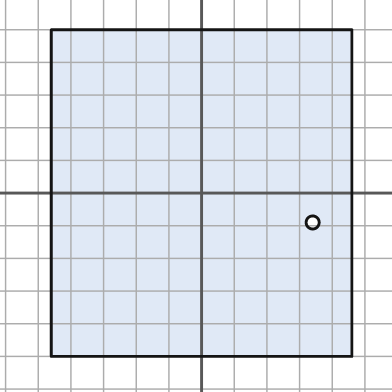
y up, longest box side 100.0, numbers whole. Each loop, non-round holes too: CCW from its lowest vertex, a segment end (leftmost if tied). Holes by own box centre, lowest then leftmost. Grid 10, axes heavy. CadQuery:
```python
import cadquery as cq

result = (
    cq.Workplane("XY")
    .moveTo(-46.0, -50.0)
    .lineTo(46.0, -50.0)
    .lineTo(46.0, 50.0)
    .lineTo(-46.0, 50.0)
    .close()
    .moveTo(34.0, -9.0)
    .circle(2.0)
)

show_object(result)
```